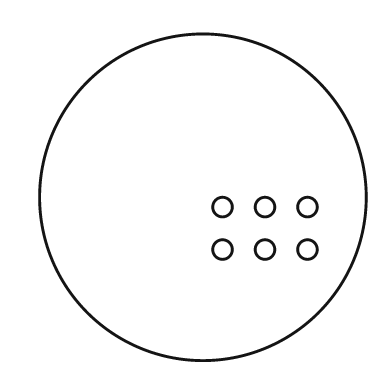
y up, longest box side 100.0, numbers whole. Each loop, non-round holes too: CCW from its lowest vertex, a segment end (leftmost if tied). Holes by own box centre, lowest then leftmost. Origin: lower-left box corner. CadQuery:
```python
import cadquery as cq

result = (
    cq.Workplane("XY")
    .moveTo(50.0, 50.0)
    .circle(50.0)
    .moveTo(56.0, 34.0)
    .circle(3.0)
    .moveTo(69.0, 34.0)
    .circle(3.0)
    .moveTo(82.0, 34.0)
    .circle(3.0)
    .moveTo(56.0, 47.0)
    .circle(3.0)
    .moveTo(69.0, 47.0)
    .circle(3.0)
    .moveTo(82.0, 47.0)
    .circle(3.0)
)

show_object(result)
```